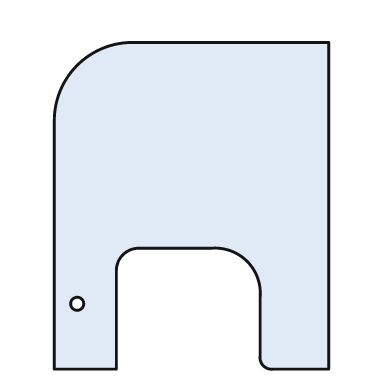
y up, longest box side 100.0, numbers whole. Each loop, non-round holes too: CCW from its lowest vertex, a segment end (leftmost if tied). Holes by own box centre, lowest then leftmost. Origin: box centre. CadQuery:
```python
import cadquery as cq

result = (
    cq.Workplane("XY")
    .moveTo(-42.0, -50.0)
    .lineTo(-23.0, -50.0)
    .lineTo(-23.0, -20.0)
    .threePointArc((-21.0, -15.0), (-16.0, -13.0))
    .lineTo(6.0, -13.0)
    .threePointArc((17.0, -17.0), (21.0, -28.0))
    .lineTo(21.0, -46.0)
    .threePointArc((22.0, -49.0), (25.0, -50.0))
    .lineTo(42.0, -50.0)
    .lineTo(42.0, 50.0)
    .lineTo(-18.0, 50.0)
    .threePointArc((-35.0, 43.0), (-42.0, 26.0))
    .close()
    .moveTo(-35.0, -30.0)
    .circle(2.0)
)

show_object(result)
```